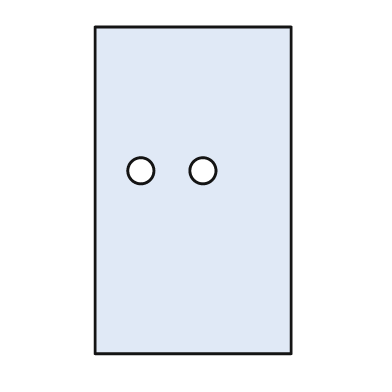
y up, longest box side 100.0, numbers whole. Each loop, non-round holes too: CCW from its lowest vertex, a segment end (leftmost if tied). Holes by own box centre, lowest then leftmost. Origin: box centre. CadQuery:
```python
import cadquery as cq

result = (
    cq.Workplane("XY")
    .moveTo(-30.0, -50.0)
    .lineTo(30.0, -50.0)
    .lineTo(30.0, 50.0)
    .lineTo(-30.0, 50.0)
    .close()
    .moveTo(-16.0, 6.0)
    .circle(4.0)
    .moveTo(3.0, 6.0)
    .circle(4.0)
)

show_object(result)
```